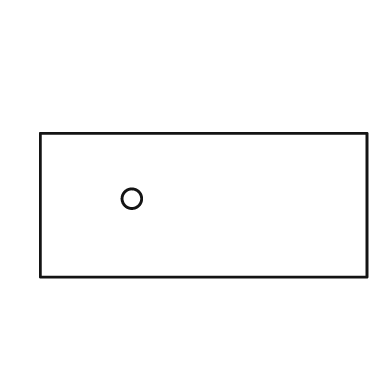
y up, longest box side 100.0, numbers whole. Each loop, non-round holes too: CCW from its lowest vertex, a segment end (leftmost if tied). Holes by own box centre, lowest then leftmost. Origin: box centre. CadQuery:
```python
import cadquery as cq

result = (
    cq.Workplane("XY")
    .moveTo(-50.0, -22.0)
    .lineTo(50.0, -22.0)
    .lineTo(50.0, 22.0)
    .lineTo(-50.0, 22.0)
    .close()
    .moveTo(-22.0, 2.0)
    .circle(3.0)
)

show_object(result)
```